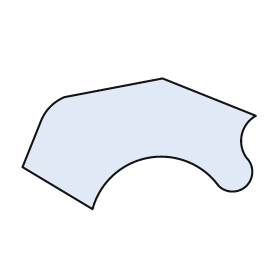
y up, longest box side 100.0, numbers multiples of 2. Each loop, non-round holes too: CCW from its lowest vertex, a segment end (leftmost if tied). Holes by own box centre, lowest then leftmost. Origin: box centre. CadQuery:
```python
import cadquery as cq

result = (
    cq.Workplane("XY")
    .moveTo(-20.0, -28.0)
    .threePointArc((4.0, -6.0), (34.0, -18.0))
    .threePointArc((46.0, -18.0), (46.0, -6.0))
    .threePointArc((44.0, 4.0), (50.0, 12.0))
    .lineTo(10.0, 28.0)
    .lineTo(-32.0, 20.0)
    .threePointArc((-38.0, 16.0), (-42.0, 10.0))
    .lineTo(-50.0, -10.0)
    .close()
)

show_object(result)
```